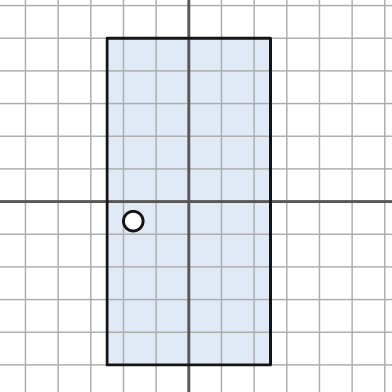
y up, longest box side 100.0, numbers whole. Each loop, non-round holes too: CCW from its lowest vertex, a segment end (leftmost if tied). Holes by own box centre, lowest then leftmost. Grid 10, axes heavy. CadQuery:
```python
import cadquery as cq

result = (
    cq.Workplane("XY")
    .moveTo(-25.0, -50.0)
    .lineTo(25.0, -50.0)
    .lineTo(25.0, 50.0)
    .lineTo(-25.0, 50.0)
    .close()
    .moveTo(-17.0, -6.0)
    .circle(3.0)
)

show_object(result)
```